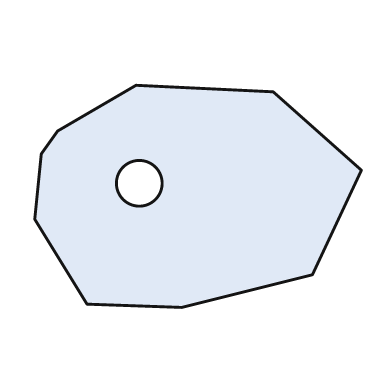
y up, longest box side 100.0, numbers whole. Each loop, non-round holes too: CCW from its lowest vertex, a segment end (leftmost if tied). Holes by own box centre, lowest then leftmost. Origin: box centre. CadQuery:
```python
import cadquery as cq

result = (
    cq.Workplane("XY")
    .moveTo(-5.0, -34.0)
    .lineTo(35.0, -24.0)
    .lineTo(50.0, 8.0)
    .lineTo(23.0, 32.0)
    .lineTo(-19.0, 34.0)
    .lineTo(-43.0, 20.0)
    .lineTo(-48.0, 13.0)
    .lineTo(-50.0, -7.0)
    .lineTo(-34.0, -33.0)
    .close()
    .moveTo(-18.0, 4.0)
    .circle(7.0)
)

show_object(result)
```